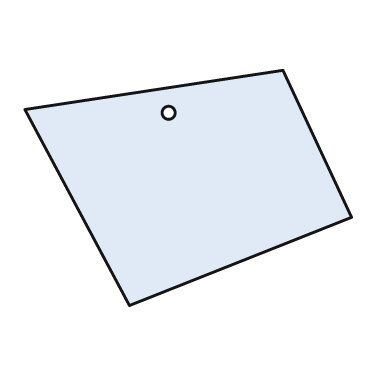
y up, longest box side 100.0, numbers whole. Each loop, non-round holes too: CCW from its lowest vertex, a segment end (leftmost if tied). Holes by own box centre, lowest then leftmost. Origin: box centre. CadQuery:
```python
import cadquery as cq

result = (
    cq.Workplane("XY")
    .moveTo(-18.0, -36.0)
    .lineTo(50.0, -9.0)
    .lineTo(29.0, 36.0)
    .lineTo(-50.0, 24.0)
    .close()
    .moveTo(-6.0, 23.0)
    .circle(2.0)
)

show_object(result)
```